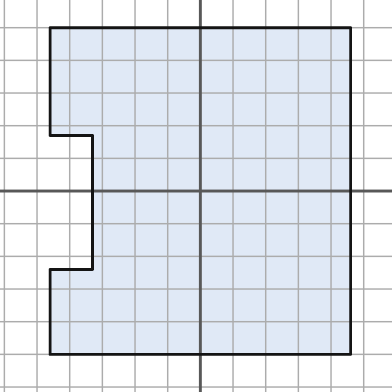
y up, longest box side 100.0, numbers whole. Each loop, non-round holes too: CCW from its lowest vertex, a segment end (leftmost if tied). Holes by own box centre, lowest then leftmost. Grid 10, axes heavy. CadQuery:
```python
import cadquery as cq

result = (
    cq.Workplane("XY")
    .moveTo(-46.0, -50.0)
    .lineTo(46.0, -50.0)
    .lineTo(46.0, 50.0)
    .lineTo(-46.0, 50.0)
    .lineTo(-46.0, 17.0)
    .lineTo(-33.0, 17.0)
    .lineTo(-33.0, -24.0)
    .lineTo(-46.0, -24.0)
    .close()
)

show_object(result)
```